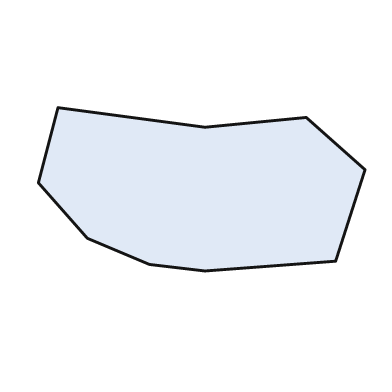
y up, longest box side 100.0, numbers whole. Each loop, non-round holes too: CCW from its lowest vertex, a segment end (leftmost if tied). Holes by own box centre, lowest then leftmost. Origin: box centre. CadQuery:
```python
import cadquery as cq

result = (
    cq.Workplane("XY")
    .moveTo(1.0, -25.0)
    .lineTo(41.0, -22.0)
    .lineTo(50.0, 6.0)
    .lineTo(32.0, 22.0)
    .lineTo(1.0, 19.0)
    .lineTo(-44.0, 25.0)
    .lineTo(-50.0, 2.0)
    .lineTo(-35.0, -15.0)
    .lineTo(-16.0, -23.0)
    .close()
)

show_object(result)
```